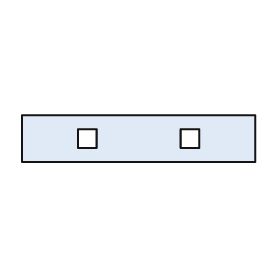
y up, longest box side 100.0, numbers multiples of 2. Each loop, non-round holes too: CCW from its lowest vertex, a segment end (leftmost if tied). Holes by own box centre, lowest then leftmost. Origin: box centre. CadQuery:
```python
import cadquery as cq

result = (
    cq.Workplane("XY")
    .moveTo(-50.0, -10.0)
    .lineTo(50.0, -10.0)
    .lineTo(50.0, 10.0)
    .lineTo(-50.0, 10.0)
    .close()
    .moveTo(-26.0, -4.0)
    .lineTo(-18.0, -4.0)
    .lineTo(-18.0, 4.0)
    .lineTo(-26.0, 4.0)
    .close()
    .moveTo(18.0, -4.0)
    .lineTo(26.0, -4.0)
    .lineTo(26.0, 4.0)
    .lineTo(18.0, 4.0)
    .close()
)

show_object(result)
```